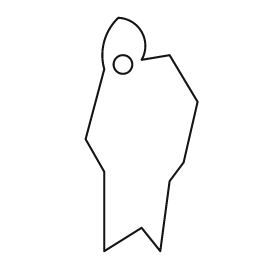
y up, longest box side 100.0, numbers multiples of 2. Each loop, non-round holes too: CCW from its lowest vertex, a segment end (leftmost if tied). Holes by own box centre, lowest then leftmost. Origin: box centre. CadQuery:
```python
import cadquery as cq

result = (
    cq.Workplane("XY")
    .moveTo(-16.0, -50.0)
    .lineTo(0.0, -40.0)
    .lineTo(8.0, -50.0)
    .lineTo(12.0, -20.0)
    .lineTo(18.0, -12.0)
    .lineTo(24.0, 14.0)
    .lineTo(12.0, 34.0)
    .lineTo(0.0, 32.0)
    .threePointArc((0.0, 44.0), (-10.0, 50.0))
    .threePointArc((-16.0, 40.0), (-16.0, 28.0))
    .lineTo(-24.0, -2.0)
    .lineTo(-16.0, -16.0)
    .close()
    .moveTo(-8.0, 30.0)
    .circle(4.0)
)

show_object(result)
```